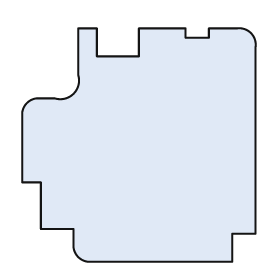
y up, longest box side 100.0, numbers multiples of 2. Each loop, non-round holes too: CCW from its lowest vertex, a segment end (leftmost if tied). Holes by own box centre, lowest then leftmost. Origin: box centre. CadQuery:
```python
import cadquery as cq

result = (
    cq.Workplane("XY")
    .moveTo(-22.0, -50.0)
    .lineTo(40.0, -50.0)
    .lineTo(40.0, -38.0)
    .lineTo(50.0, -38.0)
    .lineTo(50.0, 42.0)
    .threePointArc((48.0, 48.0), (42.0, 50.0))
    .lineTo(30.0, 50.0)
    .lineTo(30.0, 46.0)
    .lineTo(20.0, 46.0)
    .lineTo(20.0, 50.0)
    .lineTo(0.0, 50.0)
    .lineTo(0.0, 38.0)
    .lineTo(-18.0, 38.0)
    .lineTo(-18.0, 50.0)
    .lineTo(-26.0, 50.0)
    .lineTo(-26.0, 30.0)
    .threePointArc((-28.0, 22.0), (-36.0, 20.0))
    .lineTo(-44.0, 20.0)
    .threePointArc((-48.0, 18.0), (-50.0, 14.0))
    .lineTo(-50.0, -16.0)
    .lineTo(-42.0, -16.0)
    .lineTo(-42.0, -36.0)
    .lineTo(-28.0, -36.0)
    .lineTo(-28.0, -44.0)
    .threePointArc((-26.0, -48.0), (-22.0, -50.0))
    .close()
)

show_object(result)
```